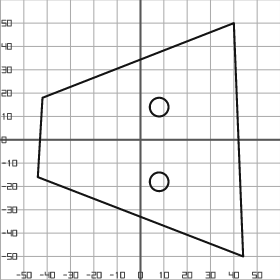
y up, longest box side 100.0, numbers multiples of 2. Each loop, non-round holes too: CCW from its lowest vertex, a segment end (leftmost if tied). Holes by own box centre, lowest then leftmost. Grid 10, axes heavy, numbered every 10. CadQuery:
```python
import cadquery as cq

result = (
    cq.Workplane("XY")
    .moveTo(44.0, -50.0)
    .lineTo(40.0, 50.0)
    .lineTo(-42.0, 18.0)
    .lineTo(-44.0, -16.0)
    .close()
    .moveTo(8.0, -18.0)
    .circle(4.0)
    .moveTo(8.0, 14.0)
    .circle(4.0)
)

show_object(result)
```